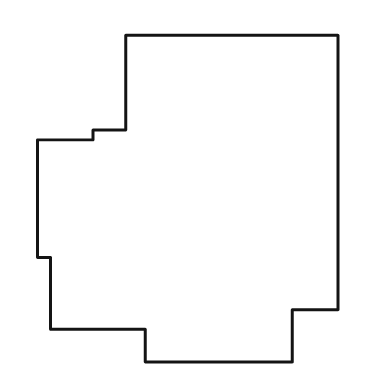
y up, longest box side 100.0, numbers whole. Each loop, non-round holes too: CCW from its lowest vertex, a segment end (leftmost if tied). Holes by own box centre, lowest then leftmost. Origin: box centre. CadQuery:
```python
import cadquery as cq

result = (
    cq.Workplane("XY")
    .moveTo(-13.0, -50.0)
    .lineTo(32.0, -50.0)
    .lineTo(32.0, -34.0)
    .lineTo(46.0, -34.0)
    .lineTo(46.0, 50.0)
    .lineTo(-19.0, 50.0)
    .lineTo(-19.0, 21.0)
    .lineTo(-29.0, 21.0)
    .lineTo(-29.0, 18.0)
    .lineTo(-46.0, 18.0)
    .lineTo(-46.0, -18.0)
    .lineTo(-42.0, -18.0)
    .lineTo(-42.0, -40.0)
    .lineTo(-13.0, -40.0)
    .close()
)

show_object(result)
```